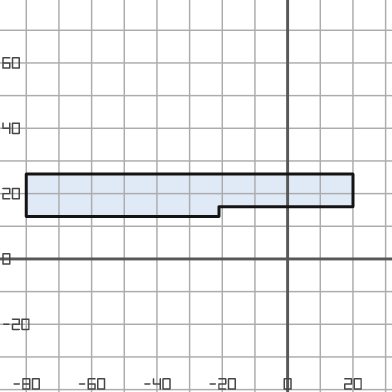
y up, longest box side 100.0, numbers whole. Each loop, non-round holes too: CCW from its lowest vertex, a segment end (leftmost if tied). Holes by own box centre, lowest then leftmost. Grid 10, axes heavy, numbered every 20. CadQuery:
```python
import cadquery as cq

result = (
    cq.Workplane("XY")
    .moveTo(-80.0, 13.0)
    .lineTo(-21.0, 13.0)
    .lineTo(-21.0, 16.0)
    .lineTo(20.0, 16.0)
    .lineTo(20.0, 26.0)
    .lineTo(-80.0, 26.0)
    .close()
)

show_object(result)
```